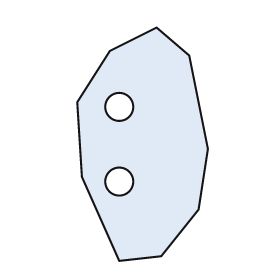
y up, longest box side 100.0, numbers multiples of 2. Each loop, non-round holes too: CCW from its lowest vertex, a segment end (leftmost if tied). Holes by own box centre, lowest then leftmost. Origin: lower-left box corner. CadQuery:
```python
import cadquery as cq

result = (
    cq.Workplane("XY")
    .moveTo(18.0, 0.0)
    .lineTo(36.0, 2.0)
    .lineTo(52.0, 22.0)
    .lineTo(56.0, 48.0)
    .lineTo(48.0, 88.0)
    .lineTo(34.0, 100.0)
    .lineTo(14.0, 90.0)
    .lineTo(0.0, 68.0)
    .lineTo(2.0, 36.0)
    .close()
    .moveTo(18.0, 34.0)
    .circle(6.0)
    .moveTo(18.0, 66.0)
    .circle(6.0)
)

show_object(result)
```